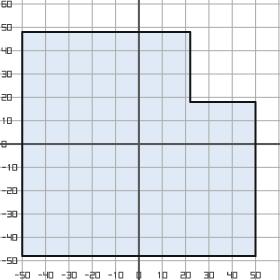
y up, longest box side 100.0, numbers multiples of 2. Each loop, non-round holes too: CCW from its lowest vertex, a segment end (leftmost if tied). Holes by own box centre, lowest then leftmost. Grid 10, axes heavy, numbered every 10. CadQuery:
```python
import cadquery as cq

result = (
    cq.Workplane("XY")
    .moveTo(-50.0, -48.0)
    .lineTo(50.0, -48.0)
    .lineTo(50.0, 18.0)
    .lineTo(22.0, 18.0)
    .lineTo(22.0, 48.0)
    .lineTo(-50.0, 48.0)
    .close()
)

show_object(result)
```